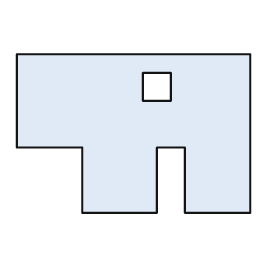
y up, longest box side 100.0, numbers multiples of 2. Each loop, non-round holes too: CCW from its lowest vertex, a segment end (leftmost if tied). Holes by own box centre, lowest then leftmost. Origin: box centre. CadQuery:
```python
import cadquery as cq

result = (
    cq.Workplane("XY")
    .moveTo(-22.0, -34.0)
    .lineTo(10.0, -34.0)
    .lineTo(10.0, -6.0)
    .lineTo(22.0, -6.0)
    .lineTo(22.0, -34.0)
    .lineTo(50.0, -34.0)
    .lineTo(50.0, 34.0)
    .lineTo(-50.0, 34.0)
    .lineTo(-50.0, -6.0)
    .lineTo(-22.0, -6.0)
    .close()
    .moveTo(4.0, 14.0)
    .lineTo(16.0, 14.0)
    .lineTo(16.0, 26.0)
    .lineTo(4.0, 26.0)
    .close()
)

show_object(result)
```